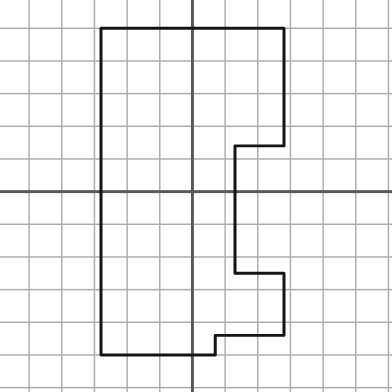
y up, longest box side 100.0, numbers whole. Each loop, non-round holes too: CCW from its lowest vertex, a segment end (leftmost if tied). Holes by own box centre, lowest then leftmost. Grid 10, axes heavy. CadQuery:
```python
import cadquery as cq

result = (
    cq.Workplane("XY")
    .moveTo(-28.0, -50.0)
    .lineTo(7.0, -50.0)
    .lineTo(7.0, -44.0)
    .lineTo(28.0, -44.0)
    .lineTo(28.0, -25.0)
    .lineTo(13.0, -25.0)
    .lineTo(13.0, 14.0)
    .lineTo(28.0, 14.0)
    .lineTo(28.0, 50.0)
    .lineTo(-28.0, 50.0)
    .close()
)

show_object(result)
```